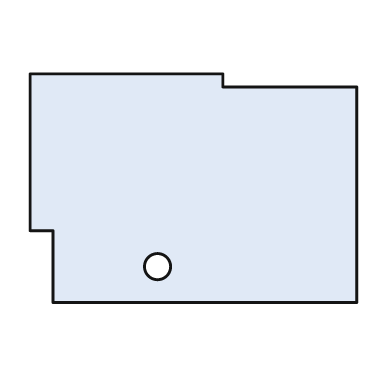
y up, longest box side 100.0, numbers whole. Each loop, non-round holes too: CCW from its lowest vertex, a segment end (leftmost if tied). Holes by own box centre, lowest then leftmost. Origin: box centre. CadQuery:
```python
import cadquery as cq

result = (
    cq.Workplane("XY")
    .moveTo(-43.0, -35.0)
    .lineTo(50.0, -35.0)
    .lineTo(50.0, 31.0)
    .lineTo(9.0, 31.0)
    .lineTo(9.0, 35.0)
    .lineTo(-50.0, 35.0)
    .lineTo(-50.0, -13.0)
    .lineTo(-43.0, -13.0)
    .close()
    .moveTo(-11.0, -24.0)
    .circle(4.0)
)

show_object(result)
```